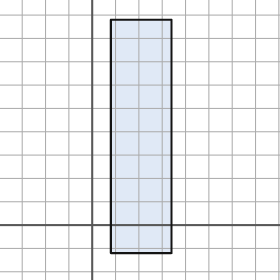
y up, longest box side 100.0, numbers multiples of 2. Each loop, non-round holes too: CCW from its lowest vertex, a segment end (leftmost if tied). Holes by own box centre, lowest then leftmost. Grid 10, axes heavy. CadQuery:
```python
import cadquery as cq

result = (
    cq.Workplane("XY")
    .moveTo(8.0, -12.0)
    .lineTo(34.0, -12.0)
    .lineTo(34.0, 88.0)
    .lineTo(8.0, 88.0)
    .close()
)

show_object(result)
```